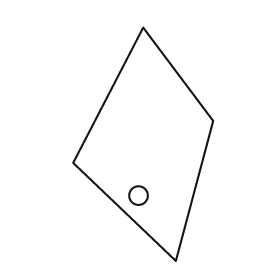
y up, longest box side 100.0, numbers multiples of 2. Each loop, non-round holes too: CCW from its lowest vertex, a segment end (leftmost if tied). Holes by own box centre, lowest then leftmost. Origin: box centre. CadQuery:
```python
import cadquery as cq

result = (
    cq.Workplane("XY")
    .moveTo(14.0, -50.0)
    .lineTo(30.0, 10.0)
    .lineTo(0.0, 50.0)
    .lineTo(-30.0, -8.0)
    .close()
    .moveTo(-2.0, -22.0)
    .circle(4.0)
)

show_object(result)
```